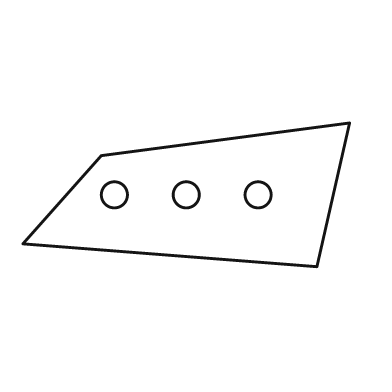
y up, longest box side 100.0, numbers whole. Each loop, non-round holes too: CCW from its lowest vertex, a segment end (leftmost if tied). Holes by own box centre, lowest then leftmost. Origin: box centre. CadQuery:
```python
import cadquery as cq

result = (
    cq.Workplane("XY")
    .moveTo(40.0, -22.0)
    .lineTo(50.0, 22.0)
    .lineTo(-26.0, 12.0)
    .lineTo(-50.0, -15.0)
    .close()
    .moveTo(-22.0, 0.0)
    .circle(4.0)
    .moveTo(0.0, 0.0)
    .circle(4.0)
    .moveTo(22.0, 0.0)
    .circle(4.0)
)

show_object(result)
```